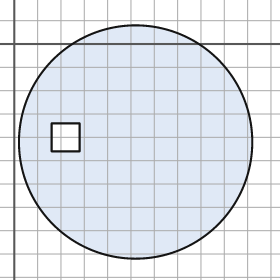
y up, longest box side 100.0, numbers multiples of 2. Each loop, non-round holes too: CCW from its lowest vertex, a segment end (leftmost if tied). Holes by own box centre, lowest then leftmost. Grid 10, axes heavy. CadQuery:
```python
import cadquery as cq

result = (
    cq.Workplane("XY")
    .moveTo(52.0, -42.0)
    .circle(50.0)
    .moveTo(16.0, -46.0)
    .lineTo(28.0, -46.0)
    .lineTo(28.0, -34.0)
    .lineTo(16.0, -34.0)
    .close()
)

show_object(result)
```